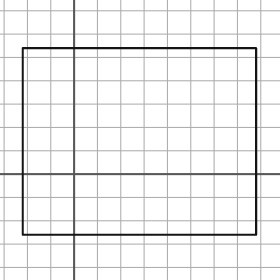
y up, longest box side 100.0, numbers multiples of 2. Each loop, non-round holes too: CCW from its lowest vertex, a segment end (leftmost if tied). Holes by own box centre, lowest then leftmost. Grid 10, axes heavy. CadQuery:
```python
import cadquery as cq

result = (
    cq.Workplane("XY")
    .moveTo(-22.0, -26.0)
    .lineTo(78.0, -26.0)
    .lineTo(78.0, 54.0)
    .lineTo(-22.0, 54.0)
    .close()
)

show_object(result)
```